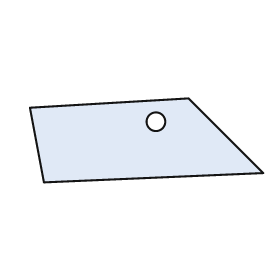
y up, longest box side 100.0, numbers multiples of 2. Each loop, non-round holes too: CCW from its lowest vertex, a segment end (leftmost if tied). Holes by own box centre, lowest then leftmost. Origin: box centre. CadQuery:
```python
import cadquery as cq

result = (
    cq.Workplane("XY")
    .moveTo(-44.0, -18.0)
    .lineTo(50.0, -14.0)
    .lineTo(18.0, 18.0)
    .lineTo(-50.0, 14.0)
    .close()
    .moveTo(4.0, 8.0)
    .circle(4.0)
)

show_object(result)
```